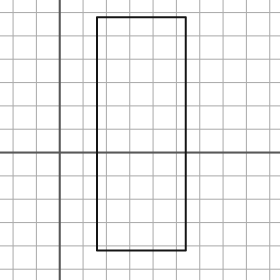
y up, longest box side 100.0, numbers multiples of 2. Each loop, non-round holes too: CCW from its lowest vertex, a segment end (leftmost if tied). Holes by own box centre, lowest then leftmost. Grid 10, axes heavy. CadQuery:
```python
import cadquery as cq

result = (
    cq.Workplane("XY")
    .moveTo(16.0, -42.0)
    .lineTo(54.0, -42.0)
    .lineTo(54.0, 58.0)
    .lineTo(16.0, 58.0)
    .close()
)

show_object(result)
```